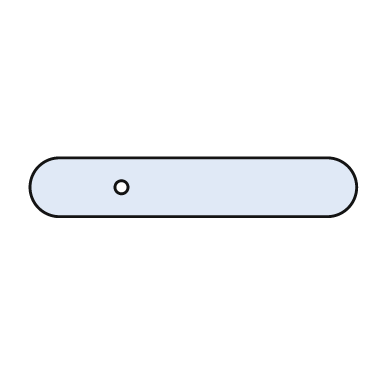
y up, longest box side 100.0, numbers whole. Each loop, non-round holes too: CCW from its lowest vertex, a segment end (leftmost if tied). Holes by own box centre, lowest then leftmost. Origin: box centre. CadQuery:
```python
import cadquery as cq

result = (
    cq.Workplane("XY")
    .moveTo(-41.0, -9.0)
    .lineTo(41.0, -9.0)
    .threePointArc((50.0, 0.0), (41.0, 9.0))
    .lineTo(-41.0, 9.0)
    .threePointArc((-50.0, 0.0), (-41.0, -9.0))
    .close()
    .moveTo(-22.0, 0.0)
    .circle(2.0)
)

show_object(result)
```